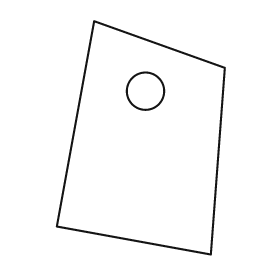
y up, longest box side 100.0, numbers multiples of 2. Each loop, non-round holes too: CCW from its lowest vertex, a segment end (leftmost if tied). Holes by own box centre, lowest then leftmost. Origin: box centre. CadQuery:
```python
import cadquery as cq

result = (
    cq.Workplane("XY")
    .moveTo(30.0, -50.0)
    .lineTo(36.0, 30.0)
    .lineTo(-20.0, 50.0)
    .lineTo(-36.0, -38.0)
    .close()
    .moveTo(2.0, 20.0)
    .circle(8.0)
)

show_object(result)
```